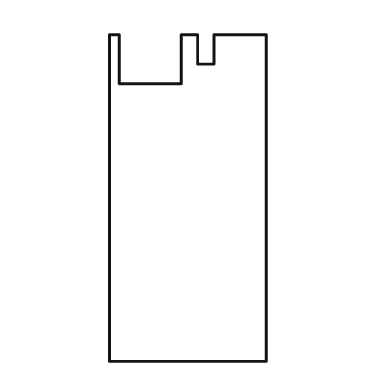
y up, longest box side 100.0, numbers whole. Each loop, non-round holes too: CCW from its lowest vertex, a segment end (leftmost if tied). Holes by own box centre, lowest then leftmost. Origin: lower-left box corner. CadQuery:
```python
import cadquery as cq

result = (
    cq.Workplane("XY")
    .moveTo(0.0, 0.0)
    .lineTo(48.0, 0.0)
    .lineTo(48.0, 100.0)
    .lineTo(32.0, 100.0)
    .lineTo(32.0, 91.0)
    .lineTo(27.0, 91.0)
    .lineTo(27.0, 100.0)
    .lineTo(22.0, 100.0)
    .lineTo(22.0, 85.0)
    .lineTo(3.0, 85.0)
    .lineTo(3.0, 100.0)
    .lineTo(0.0, 100.0)
    .close()
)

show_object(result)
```